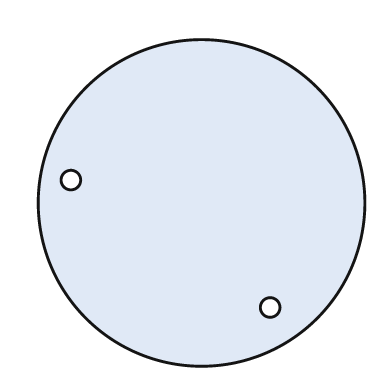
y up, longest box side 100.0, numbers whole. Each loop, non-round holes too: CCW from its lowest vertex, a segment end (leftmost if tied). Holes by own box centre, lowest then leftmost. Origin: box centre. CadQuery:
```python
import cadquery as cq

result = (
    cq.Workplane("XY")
    .moveTo(0.0, 0.0)
    .circle(50.0)
    .moveTo(21.0, -32.0)
    .circle(3.0)
    .moveTo(-40.0, 7.0)
    .circle(3.0)
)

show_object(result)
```